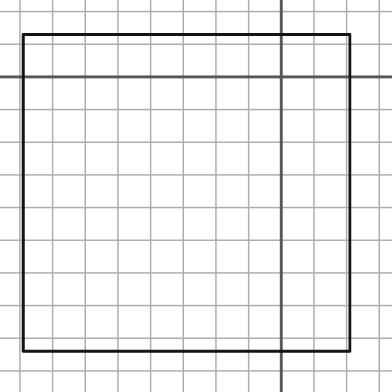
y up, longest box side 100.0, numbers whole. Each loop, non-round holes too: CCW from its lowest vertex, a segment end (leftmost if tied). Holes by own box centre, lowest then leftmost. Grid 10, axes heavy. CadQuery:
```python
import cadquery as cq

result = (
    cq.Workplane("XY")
    .moveTo(-79.0, -84.0)
    .lineTo(21.0, -84.0)
    .lineTo(21.0, 13.0)
    .lineTo(-79.0, 13.0)
    .close()
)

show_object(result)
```